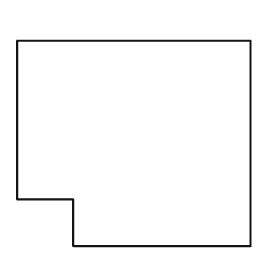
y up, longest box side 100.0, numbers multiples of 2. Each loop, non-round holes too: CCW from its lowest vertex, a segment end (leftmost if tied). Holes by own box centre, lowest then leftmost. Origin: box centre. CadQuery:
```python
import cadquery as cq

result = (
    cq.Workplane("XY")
    .moveTo(-26.0, -44.0)
    .lineTo(50.0, -44.0)
    .lineTo(50.0, 44.0)
    .lineTo(-50.0, 44.0)
    .lineTo(-50.0, -24.0)
    .lineTo(-26.0, -24.0)
    .close()
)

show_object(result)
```